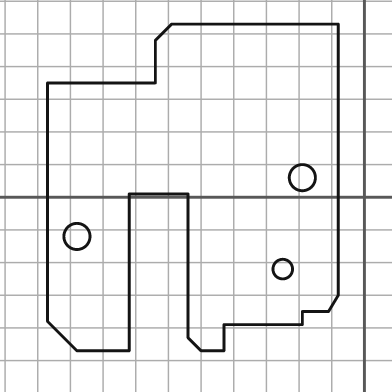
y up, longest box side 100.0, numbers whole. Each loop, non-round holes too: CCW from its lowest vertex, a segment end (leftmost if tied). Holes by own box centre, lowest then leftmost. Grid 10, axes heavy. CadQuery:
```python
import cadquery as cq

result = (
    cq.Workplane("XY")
    .moveTo(-88.0, -47.0)
    .lineTo(-72.0, -47.0)
    .lineTo(-72.0, 1.0)
    .lineTo(-54.0, 1.0)
    .lineTo(-54.0, -43.0)
    .lineTo(-50.0, -47.0)
    .lineTo(-43.0, -47.0)
    .lineTo(-43.0, -39.0)
    .lineTo(-19.0, -39.0)
    .lineTo(-19.0, -35.0)
    .lineTo(-11.0, -35.0)
    .lineTo(-8.0, -30.0)
    .lineTo(-8.0, 53.0)
    .lineTo(-59.0, 53.0)
    .lineTo(-64.0, 48.0)
    .lineTo(-64.0, 35.0)
    .lineTo(-97.0, 35.0)
    .lineTo(-97.0, -38.0)
    .close()
    .moveTo(-25.0, -22.0)
    .circle(3.0)
    .moveTo(-88.0, -12.0)
    .circle(4.0)
    .moveTo(-19.0, 6.0)
    .circle(4.0)
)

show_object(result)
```